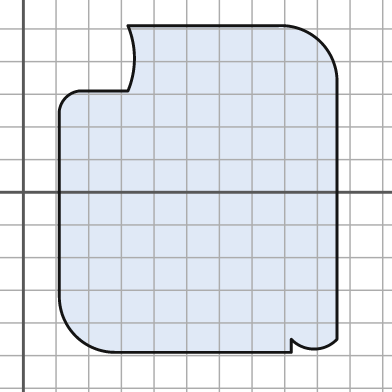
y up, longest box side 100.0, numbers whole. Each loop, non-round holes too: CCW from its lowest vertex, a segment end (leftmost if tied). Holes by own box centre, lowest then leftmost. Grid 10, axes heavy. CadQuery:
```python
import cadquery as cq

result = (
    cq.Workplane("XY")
    .moveTo(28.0, -49.0)
    .lineTo(82.0, -49.0)
    .lineTo(82.0, -45.0)
    .threePointArc((89.0, -48.0), (96.0, -45.0))
    .lineTo(96.0, 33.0)
    .threePointArc((91.0, 46.0), (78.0, 51.0))
    .lineTo(32.0, 51.0)
    .threePointArc((34.0, 41.0), (32.0, 31.0))
    .lineTo(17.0, 31.0)
    .threePointArc((13.0, 29.0), (11.0, 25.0))
    .lineTo(11.0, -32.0)
    .threePointArc((16.0, -44.0), (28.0, -49.0))
    .close()
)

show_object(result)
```